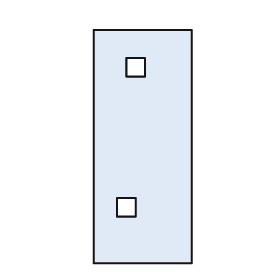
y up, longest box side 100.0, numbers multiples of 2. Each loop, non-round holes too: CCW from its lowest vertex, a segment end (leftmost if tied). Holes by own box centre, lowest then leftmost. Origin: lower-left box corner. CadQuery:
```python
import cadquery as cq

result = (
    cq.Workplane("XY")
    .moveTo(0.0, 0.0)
    .lineTo(42.0, 0.0)
    .lineTo(42.0, 100.0)
    .lineTo(0.0, 100.0)
    .close()
    .moveTo(10.0, 20.0)
    .lineTo(18.0, 20.0)
    .lineTo(18.0, 28.0)
    .lineTo(10.0, 28.0)
    .close()
    .moveTo(14.0, 80.0)
    .lineTo(22.0, 80.0)
    .lineTo(22.0, 88.0)
    .lineTo(14.0, 88.0)
    .close()
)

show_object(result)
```